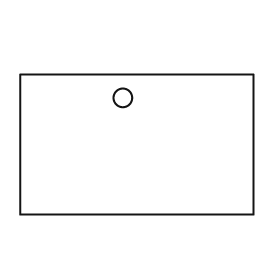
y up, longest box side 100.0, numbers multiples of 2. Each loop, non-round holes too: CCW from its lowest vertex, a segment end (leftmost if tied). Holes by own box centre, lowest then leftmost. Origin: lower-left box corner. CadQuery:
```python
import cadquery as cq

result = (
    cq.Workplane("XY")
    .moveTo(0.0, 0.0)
    .lineTo(100.0, 0.0)
    .lineTo(100.0, 60.0)
    .lineTo(0.0, 60.0)
    .close()
    .moveTo(44.0, 50.0)
    .circle(4.0)
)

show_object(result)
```